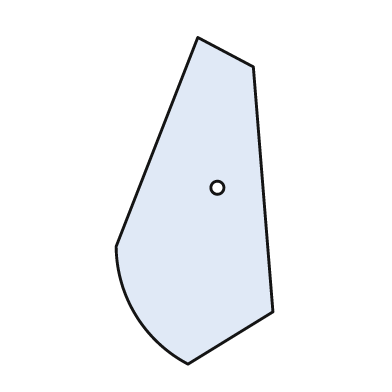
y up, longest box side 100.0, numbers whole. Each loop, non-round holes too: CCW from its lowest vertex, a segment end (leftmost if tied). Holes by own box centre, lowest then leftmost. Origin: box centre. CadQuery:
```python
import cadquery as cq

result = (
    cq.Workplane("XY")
    .moveTo(-2.0, -50.0)
    .lineTo(24.0, -34.0)
    .lineTo(18.0, 41.0)
    .lineTo(1.0, 50.0)
    .lineTo(-24.0, -14.0)
    .threePointArc((-18.0, -35.0), (-2.0, -50.0))
    .close()
    .moveTo(7.0, 4.0)
    .circle(2.0)
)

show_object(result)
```